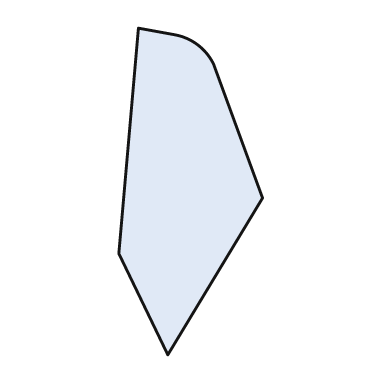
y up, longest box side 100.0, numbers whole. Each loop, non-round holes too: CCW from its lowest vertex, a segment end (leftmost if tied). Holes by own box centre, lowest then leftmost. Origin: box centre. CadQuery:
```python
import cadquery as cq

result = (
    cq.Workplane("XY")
    .moveTo(-7.0, -50.0)
    .lineTo(22.0, -2.0)
    .lineTo(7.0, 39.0)
    .threePointArc((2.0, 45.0), (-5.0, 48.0))
    .lineTo(-16.0, 50.0)
    .lineTo(-22.0, -19.0)
    .close()
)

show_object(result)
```